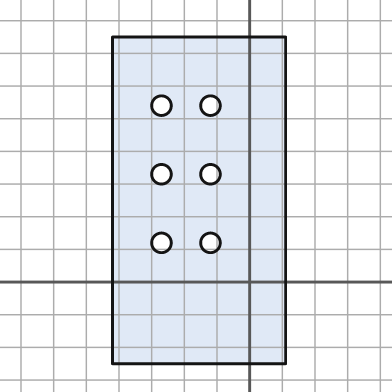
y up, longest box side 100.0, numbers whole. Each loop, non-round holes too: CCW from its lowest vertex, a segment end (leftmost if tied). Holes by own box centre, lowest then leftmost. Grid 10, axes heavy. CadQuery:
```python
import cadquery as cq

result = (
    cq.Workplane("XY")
    .moveTo(-42.0, -25.0)
    .lineTo(11.0, -25.0)
    .lineTo(11.0, 75.0)
    .lineTo(-42.0, 75.0)
    .close()
    .moveTo(-27.0, 12.0)
    .circle(3.0)
    .moveTo(-12.0, 12.0)
    .circle(3.0)
    .moveTo(-27.0, 33.0)
    .circle(3.0)
    .moveTo(-12.0, 33.0)
    .circle(3.0)
    .moveTo(-27.0, 54.0)
    .circle(3.0)
    .moveTo(-12.0, 54.0)
    .circle(3.0)
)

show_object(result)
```